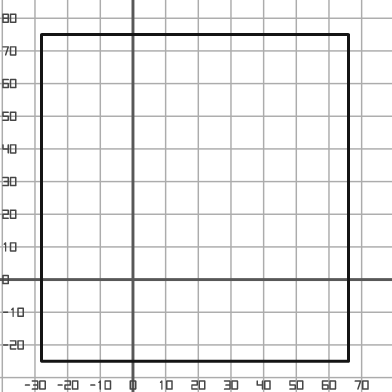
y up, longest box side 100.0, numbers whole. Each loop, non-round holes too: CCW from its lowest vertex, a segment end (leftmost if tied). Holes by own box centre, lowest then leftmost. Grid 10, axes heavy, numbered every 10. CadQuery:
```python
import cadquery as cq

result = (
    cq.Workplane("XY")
    .moveTo(-28.0, -25.0)
    .lineTo(66.0, -25.0)
    .lineTo(66.0, 75.0)
    .lineTo(-28.0, 75.0)
    .close()
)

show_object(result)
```